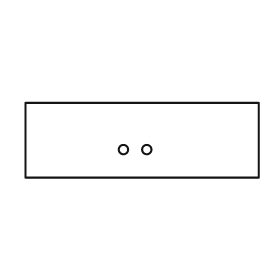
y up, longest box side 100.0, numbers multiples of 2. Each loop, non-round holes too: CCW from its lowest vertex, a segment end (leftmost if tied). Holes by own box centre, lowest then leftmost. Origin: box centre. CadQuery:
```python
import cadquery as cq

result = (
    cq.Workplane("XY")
    .moveTo(-50.0, -16.0)
    .lineTo(50.0, -16.0)
    .lineTo(50.0, 16.0)
    .lineTo(-50.0, 16.0)
    .close()
    .moveTo(-8.0, -4.0)
    .circle(2.0)
    .moveTo(2.0, -4.0)
    .circle(2.0)
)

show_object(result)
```